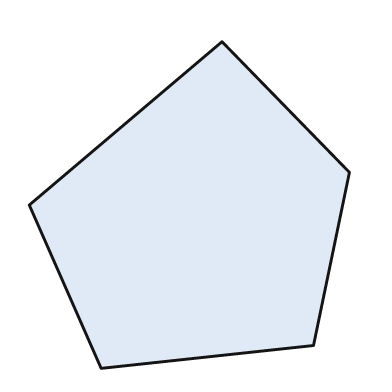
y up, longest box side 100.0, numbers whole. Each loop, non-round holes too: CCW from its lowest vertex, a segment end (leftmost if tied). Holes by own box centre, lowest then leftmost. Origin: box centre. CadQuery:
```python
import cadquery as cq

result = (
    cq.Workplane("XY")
    .moveTo(-27.0, -50.0)
    .lineTo(38.0, -43.0)
    .lineTo(49.0, 10.0)
    .lineTo(10.0, 50.0)
    .lineTo(-49.0, 0.0)
    .close()
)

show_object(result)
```